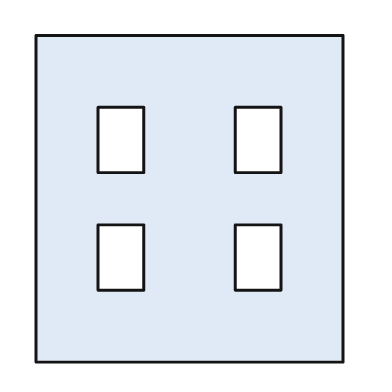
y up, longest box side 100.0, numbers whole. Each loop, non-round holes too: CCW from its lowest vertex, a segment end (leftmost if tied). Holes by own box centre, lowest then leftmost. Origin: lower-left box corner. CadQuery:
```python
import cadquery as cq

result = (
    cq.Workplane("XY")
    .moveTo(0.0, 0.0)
    .lineTo(94.0, 0.0)
    .lineTo(94.0, 100.0)
    .lineTo(0.0, 100.0)
    .close()
    .moveTo(19.0, 22.0)
    .lineTo(33.0, 22.0)
    .lineTo(33.0, 42.0)
    .lineTo(19.0, 42.0)
    .close()
    .moveTo(61.0, 22.0)
    .lineTo(75.0, 22.0)
    .lineTo(75.0, 42.0)
    .lineTo(61.0, 42.0)
    .close()
    .moveTo(19.0, 58.0)
    .lineTo(33.0, 58.0)
    .lineTo(33.0, 78.0)
    .lineTo(19.0, 78.0)
    .close()
    .moveTo(61.0, 58.0)
    .lineTo(75.0, 58.0)
    .lineTo(75.0, 78.0)
    .lineTo(61.0, 78.0)
    .close()
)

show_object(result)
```